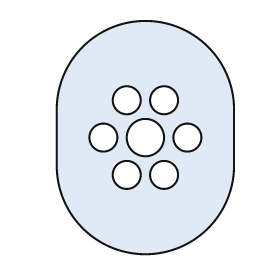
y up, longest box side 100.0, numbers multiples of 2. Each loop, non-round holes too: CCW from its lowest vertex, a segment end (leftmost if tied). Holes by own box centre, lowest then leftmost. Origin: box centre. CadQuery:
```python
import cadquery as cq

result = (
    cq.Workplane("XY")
    .moveTo(-38.0, -12.0)
    .threePointArc((0.0, -50.0), (38.0, -12.0))
    .lineTo(38.0, 12.0)
    .threePointArc((0.0, 50.0), (-38.0, 12.0))
    .close()
    .moveTo(-8.0, -16.0)
    .circle(6.0)
    .moveTo(8.0, -16.0)
    .circle(6.0)
    .moveTo(-18.0, 0.0)
    .circle(6.0)
    .moveTo(0.0, 0.0)
    .circle(8.0)
    .moveTo(18.0, 0.0)
    .circle(6.0)
    .moveTo(-8.0, 16.0)
    .circle(6.0)
    .moveTo(8.0, 16.0)
    .circle(6.0)
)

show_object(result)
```